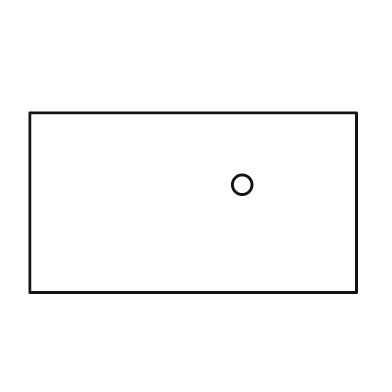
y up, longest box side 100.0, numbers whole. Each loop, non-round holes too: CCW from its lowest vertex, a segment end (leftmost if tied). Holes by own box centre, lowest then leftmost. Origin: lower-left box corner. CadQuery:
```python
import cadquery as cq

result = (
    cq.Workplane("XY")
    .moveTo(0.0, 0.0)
    .lineTo(100.0, 0.0)
    .lineTo(100.0, 55.0)
    .lineTo(0.0, 55.0)
    .close()
    .moveTo(65.0, 33.0)
    .circle(3.0)
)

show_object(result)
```